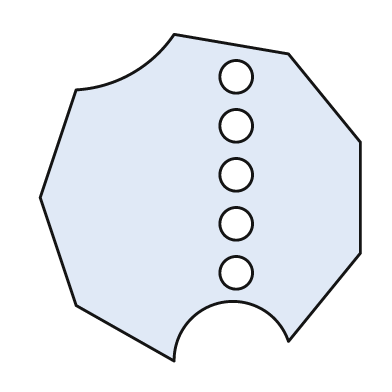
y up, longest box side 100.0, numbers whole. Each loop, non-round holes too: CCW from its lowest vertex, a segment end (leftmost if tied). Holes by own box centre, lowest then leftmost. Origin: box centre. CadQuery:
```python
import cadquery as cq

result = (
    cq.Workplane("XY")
    .moveTo(-8.0, -50.0)
    .threePointArc((7.0, -32.0), (27.0, -44.0))
    .lineTo(49.0, -17.0)
    .lineTo(49.0, 17.0)
    .lineTo(27.0, 44.0)
    .lineTo(-8.0, 50.0)
    .threePointArc((-21.0, 38.0), (-38.0, 33.0))
    .lineTo(-49.0, 0.0)
    .lineTo(-38.0, -33.0)
    .close()
    .moveTo(11.0, -23.0)
    .circle(5.0)
    .moveTo(11.0, -8.0)
    .circle(5.0)
    .moveTo(11.0, 7.0)
    .circle(5.0)
    .moveTo(11.0, 22.0)
    .circle(5.0)
    .moveTo(11.0, 37.0)
    .circle(5.0)
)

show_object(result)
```